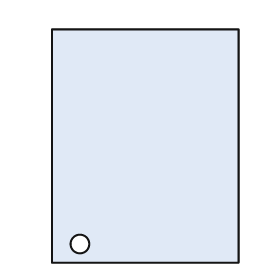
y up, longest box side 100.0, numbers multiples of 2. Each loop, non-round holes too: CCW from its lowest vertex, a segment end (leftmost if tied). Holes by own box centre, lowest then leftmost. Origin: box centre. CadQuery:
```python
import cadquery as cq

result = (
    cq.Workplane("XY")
    .moveTo(-40.0, -50.0)
    .lineTo(40.0, -50.0)
    .lineTo(40.0, 50.0)
    .lineTo(-40.0, 50.0)
    .close()
    .moveTo(-28.0, -42.0)
    .circle(4.0)
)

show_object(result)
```